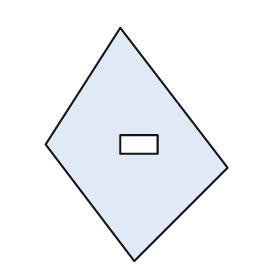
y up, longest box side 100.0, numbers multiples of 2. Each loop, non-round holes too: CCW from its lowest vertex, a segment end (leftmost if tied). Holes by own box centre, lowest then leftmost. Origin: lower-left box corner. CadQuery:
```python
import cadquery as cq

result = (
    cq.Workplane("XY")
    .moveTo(38.0, 0.0)
    .lineTo(78.0, 40.0)
    .lineTo(32.0, 100.0)
    .lineTo(0.0, 50.0)
    .close()
    .moveTo(32.0, 46.0)
    .lineTo(48.0, 46.0)
    .lineTo(48.0, 54.0)
    .lineTo(32.0, 54.0)
    .close()
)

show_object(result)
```